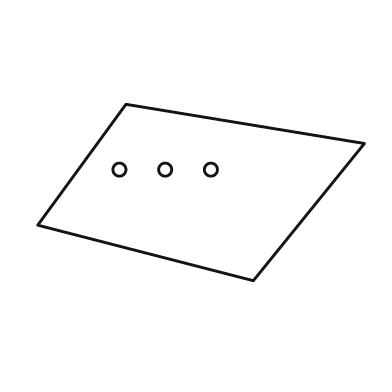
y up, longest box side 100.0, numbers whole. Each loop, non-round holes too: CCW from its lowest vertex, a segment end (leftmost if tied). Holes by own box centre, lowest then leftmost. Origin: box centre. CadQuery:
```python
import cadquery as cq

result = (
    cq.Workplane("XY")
    .moveTo(16.0, -27.0)
    .lineTo(50.0, 15.0)
    .lineTo(-23.0, 27.0)
    .lineTo(-50.0, -10.0)
    .close()
    .moveTo(-25.0, 7.0)
    .circle(2.0)
    .moveTo(-11.0, 7.0)
    .circle(2.0)
    .moveTo(3.0, 7.0)
    .circle(2.0)
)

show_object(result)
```